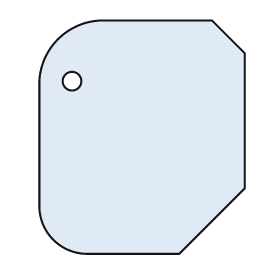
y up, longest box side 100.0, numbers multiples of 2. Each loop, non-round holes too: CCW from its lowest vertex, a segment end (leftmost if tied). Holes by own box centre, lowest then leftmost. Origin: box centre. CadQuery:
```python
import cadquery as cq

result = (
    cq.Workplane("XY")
    .moveTo(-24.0, -50.0)
    .lineTo(16.0, -50.0)
    .lineTo(44.0, -22.0)
    .lineTo(44.0, 36.0)
    .lineTo(30.0, 50.0)
    .lineTo(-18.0, 50.0)
    .threePointArc((-36.0, 42.0), (-44.0, 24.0))
    .lineTo(-44.0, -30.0)
    .threePointArc((-38.0, -44.0), (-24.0, -50.0))
    .close()
    .moveTo(-30.0, 24.0)
    .circle(4.0)
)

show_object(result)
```